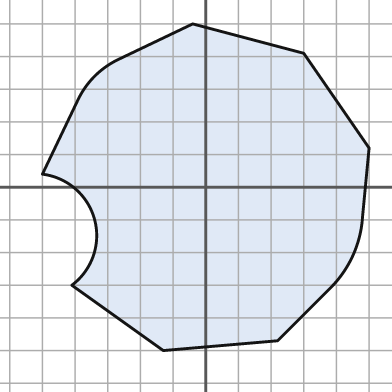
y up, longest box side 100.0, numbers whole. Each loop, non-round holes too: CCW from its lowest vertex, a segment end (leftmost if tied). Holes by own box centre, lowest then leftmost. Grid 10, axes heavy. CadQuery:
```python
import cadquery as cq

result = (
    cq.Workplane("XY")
    .moveTo(-13.0, -50.0)
    .lineTo(22.0, -47.0)
    .lineTo(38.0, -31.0)
    .threePointArc((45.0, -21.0), (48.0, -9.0))
    .lineTo(50.0, 12.0)
    .lineTo(30.0, 41.0)
    .lineTo(-4.0, 50.0)
    .lineTo(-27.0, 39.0)
    .threePointArc((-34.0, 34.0), (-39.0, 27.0))
    .lineTo(-50.0, 4.0)
    .threePointArc((-34.0, -10.0), (-41.0, -30.0))
    .close()
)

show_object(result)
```